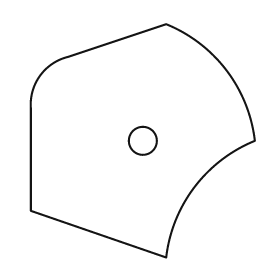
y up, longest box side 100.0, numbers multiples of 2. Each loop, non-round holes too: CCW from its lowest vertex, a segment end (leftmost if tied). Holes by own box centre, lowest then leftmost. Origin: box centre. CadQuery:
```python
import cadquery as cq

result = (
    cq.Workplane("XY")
    .moveTo(10.0, -50.0)
    .threePointArc((22.0, -20.0), (48.0, 0.0))
    .threePointArc((36.0, 30.0), (10.0, 50.0))
    .lineTo(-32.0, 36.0)
    .threePointArc((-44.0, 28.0), (-48.0, 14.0))
    .lineTo(-48.0, -30.0)
    .close()
    .moveTo(0.0, 0.0)
    .circle(6.0)
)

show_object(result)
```